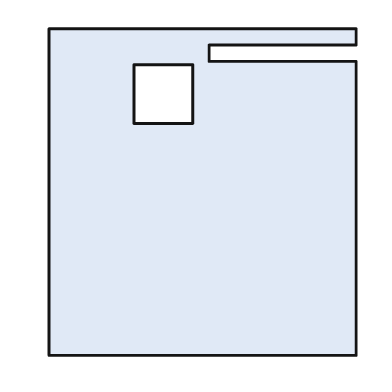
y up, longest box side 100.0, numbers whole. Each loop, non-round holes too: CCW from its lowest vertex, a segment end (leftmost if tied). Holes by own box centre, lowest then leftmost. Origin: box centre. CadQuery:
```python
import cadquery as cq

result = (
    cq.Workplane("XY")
    .moveTo(-47.0, -50.0)
    .lineTo(47.0, -50.0)
    .lineTo(47.0, 40.0)
    .lineTo(2.0, 40.0)
    .lineTo(2.0, 45.0)
    .lineTo(47.0, 45.0)
    .lineTo(47.0, 50.0)
    .lineTo(-47.0, 50.0)
    .close()
    .moveTo(-21.0, 21.0)
    .lineTo(-3.0, 21.0)
    .lineTo(-3.0, 39.0)
    .lineTo(-21.0, 39.0)
    .close()
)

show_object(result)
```